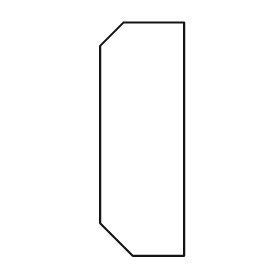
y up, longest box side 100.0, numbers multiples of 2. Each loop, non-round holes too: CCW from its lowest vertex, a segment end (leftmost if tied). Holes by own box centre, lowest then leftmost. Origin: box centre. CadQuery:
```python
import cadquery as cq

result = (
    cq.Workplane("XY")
    .moveTo(-4.0, -50.0)
    .lineTo(18.0, -50.0)
    .lineTo(18.0, 50.0)
    .lineTo(-8.0, 50.0)
    .lineTo(-18.0, 40.0)
    .lineTo(-18.0, -36.0)
    .close()
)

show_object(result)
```